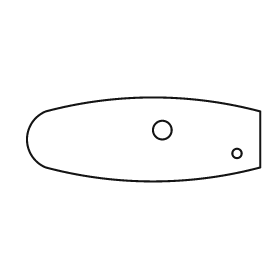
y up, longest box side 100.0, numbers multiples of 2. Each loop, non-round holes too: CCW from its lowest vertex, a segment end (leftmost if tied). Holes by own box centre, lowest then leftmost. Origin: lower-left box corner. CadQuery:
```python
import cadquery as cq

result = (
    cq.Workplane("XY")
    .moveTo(8.0, 6.0)
    .threePointArc((54.0, 0.0), (100.0, 6.0))
    .lineTo(100.0, 30.0)
    .threePointArc((54.0, 36.0), (8.0, 30.0))
    .threePointArc((0.0, 18.0), (8.0, 6.0))
    .close()
    .moveTo(90.0, 12.0)
    .circle(2.0)
    .moveTo(58.0, 22.0)
    .circle(4.0)
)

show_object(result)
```